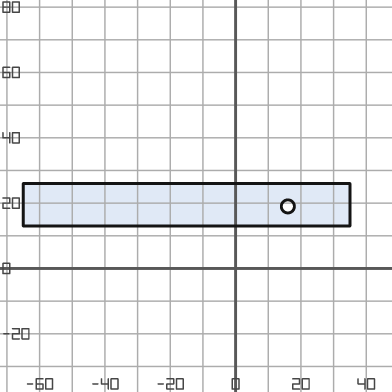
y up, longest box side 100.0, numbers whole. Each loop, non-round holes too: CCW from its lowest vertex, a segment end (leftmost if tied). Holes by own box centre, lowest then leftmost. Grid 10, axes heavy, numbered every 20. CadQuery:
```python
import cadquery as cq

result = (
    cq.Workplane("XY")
    .moveTo(-65.0, 13.0)
    .lineTo(35.0, 13.0)
    .lineTo(35.0, 26.0)
    .lineTo(-65.0, 26.0)
    .close()
    .moveTo(16.0, 19.0)
    .circle(2.0)
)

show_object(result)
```